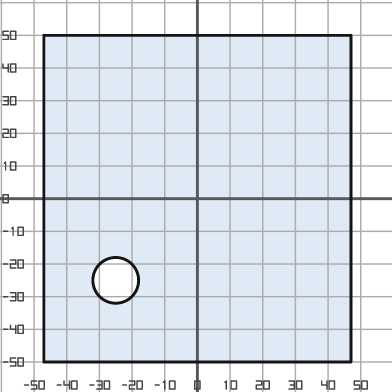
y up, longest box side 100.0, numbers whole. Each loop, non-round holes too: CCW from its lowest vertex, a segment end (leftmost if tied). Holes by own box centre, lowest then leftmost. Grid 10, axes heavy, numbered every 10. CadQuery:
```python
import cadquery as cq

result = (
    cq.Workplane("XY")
    .moveTo(-47.0, -50.0)
    .lineTo(47.0, -50.0)
    .lineTo(47.0, 50.0)
    .lineTo(-47.0, 50.0)
    .close()
    .moveTo(-25.0, -25.0)
    .circle(7.0)
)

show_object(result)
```